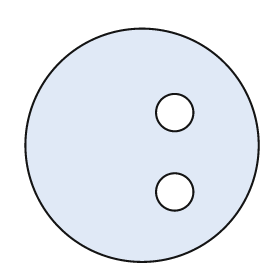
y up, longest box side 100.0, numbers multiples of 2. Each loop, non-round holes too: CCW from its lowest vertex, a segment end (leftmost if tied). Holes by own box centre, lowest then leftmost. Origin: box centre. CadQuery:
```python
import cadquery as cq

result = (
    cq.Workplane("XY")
    .moveTo(0.0, 0.0)
    .circle(50.0)
    .moveTo(14.0, -20.0)
    .circle(8.0)
    .moveTo(14.0, 14.0)
    .circle(8.0)
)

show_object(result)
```